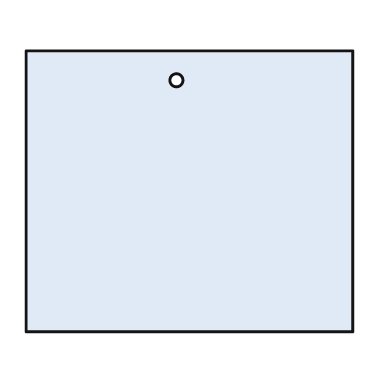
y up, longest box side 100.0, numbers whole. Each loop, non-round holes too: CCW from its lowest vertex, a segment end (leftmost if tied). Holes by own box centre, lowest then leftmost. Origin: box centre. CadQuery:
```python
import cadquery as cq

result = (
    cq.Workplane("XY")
    .moveTo(-50.0, -43.0)
    .lineTo(50.0, -43.0)
    .lineTo(50.0, 43.0)
    .lineTo(-50.0, 43.0)
    .close()
    .moveTo(-4.0, 34.0)
    .circle(2.0)
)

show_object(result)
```